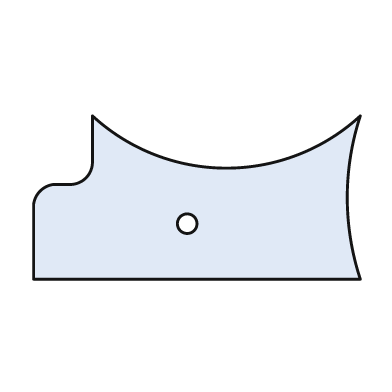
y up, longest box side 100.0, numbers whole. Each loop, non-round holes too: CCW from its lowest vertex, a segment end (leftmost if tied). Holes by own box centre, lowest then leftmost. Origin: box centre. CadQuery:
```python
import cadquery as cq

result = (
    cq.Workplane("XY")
    .moveTo(-50.0, -25.0)
    .lineTo(50.0, -25.0)
    .threePointArc((46.0, 0.0), (50.0, 25.0))
    .threePointArc((9.0, 9.0), (-32.0, 25.0))
    .lineTo(-32.0, 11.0)
    .threePointArc((-34.0, 6.0), (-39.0, 4.0))
    .lineTo(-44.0, 4.0)
    .threePointArc((-48.0, 2.0), (-50.0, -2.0))
    .close()
    .moveTo(-3.0, -8.0)
    .circle(3.0)
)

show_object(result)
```